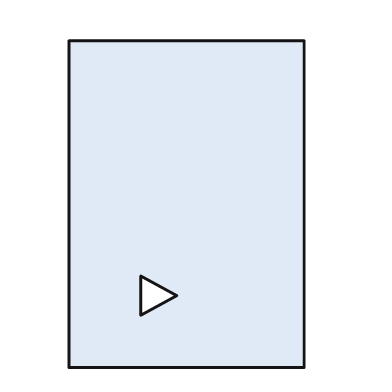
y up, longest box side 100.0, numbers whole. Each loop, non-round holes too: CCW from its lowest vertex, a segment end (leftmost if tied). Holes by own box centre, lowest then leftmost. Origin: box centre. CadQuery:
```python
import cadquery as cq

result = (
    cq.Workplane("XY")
    .moveTo(-36.0, -50.0)
    .lineTo(36.0, -50.0)
    .lineTo(36.0, 50.0)
    .lineTo(-36.0, 50.0)
    .close()
    .moveTo(-14.0, -34.0)
    .lineTo(-3.0, -28.0)
    .lineTo(-14.0, -22.0)
    .close()
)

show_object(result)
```